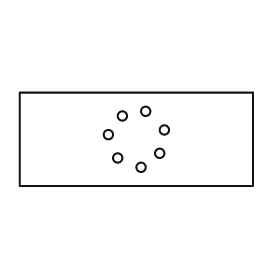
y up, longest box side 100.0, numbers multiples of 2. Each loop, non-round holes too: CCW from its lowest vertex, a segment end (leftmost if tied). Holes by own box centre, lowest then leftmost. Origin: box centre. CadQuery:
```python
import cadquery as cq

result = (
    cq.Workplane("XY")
    .moveTo(-50.0, -20.0)
    .lineTo(50.0, -20.0)
    .lineTo(50.0, 20.0)
    .lineTo(-50.0, 20.0)
    .close()
    .moveTo(2.0, -12.0)
    .circle(2.0)
    .moveTo(-8.0, -8.0)
    .circle(2.0)
    .moveTo(10.0, -6.0)
    .circle(2.0)
    .moveTo(-12.0, 2.0)
    .circle(2.0)
    .moveTo(12.0, 4.0)
    .circle(2.0)
    .moveTo(-6.0, 10.0)
    .circle(2.0)
    .moveTo(4.0, 12.0)
    .circle(2.0)
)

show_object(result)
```